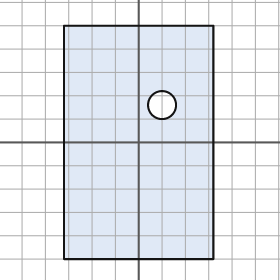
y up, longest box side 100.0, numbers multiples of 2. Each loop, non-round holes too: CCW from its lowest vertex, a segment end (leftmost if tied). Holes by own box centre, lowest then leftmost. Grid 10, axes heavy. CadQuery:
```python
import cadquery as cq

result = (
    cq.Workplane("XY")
    .moveTo(-32.0, -50.0)
    .lineTo(32.0, -50.0)
    .lineTo(32.0, 50.0)
    .lineTo(-32.0, 50.0)
    .close()
    .moveTo(10.0, 16.0)
    .circle(6.0)
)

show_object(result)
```